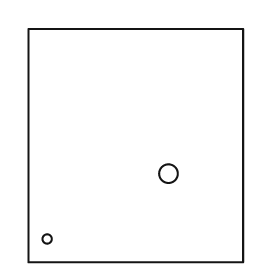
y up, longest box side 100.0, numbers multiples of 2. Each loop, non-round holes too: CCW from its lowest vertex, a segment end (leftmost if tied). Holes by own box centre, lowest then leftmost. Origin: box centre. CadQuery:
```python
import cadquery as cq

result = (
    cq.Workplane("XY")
    .moveTo(-46.0, -50.0)
    .lineTo(46.0, -50.0)
    .lineTo(46.0, 50.0)
    .lineTo(-46.0, 50.0)
    .close()
    .moveTo(-38.0, -40.0)
    .circle(2.0)
    .moveTo(14.0, -12.0)
    .circle(4.0)
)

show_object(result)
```